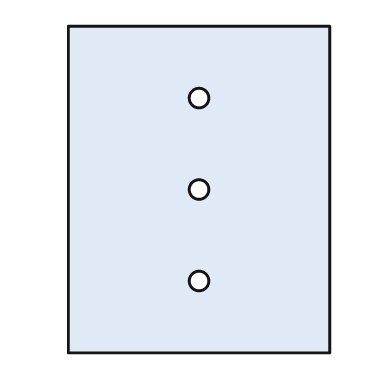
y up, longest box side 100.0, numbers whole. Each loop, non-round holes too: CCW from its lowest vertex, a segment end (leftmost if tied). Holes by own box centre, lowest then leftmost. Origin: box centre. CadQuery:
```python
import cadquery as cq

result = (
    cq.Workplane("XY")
    .moveTo(-40.0, -50.0)
    .lineTo(40.0, -50.0)
    .lineTo(40.0, 50.0)
    .lineTo(-40.0, 50.0)
    .close()
    .moveTo(0.0, -28.0)
    .circle(3.0)
    .moveTo(0.0, 0.0)
    .circle(3.0)
    .moveTo(0.0, 28.0)
    .circle(3.0)
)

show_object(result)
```